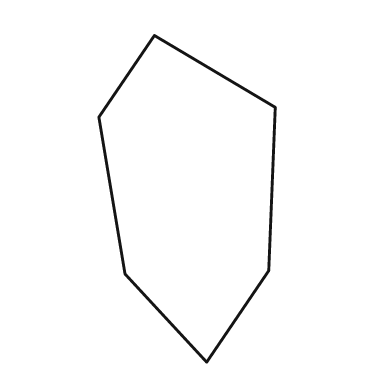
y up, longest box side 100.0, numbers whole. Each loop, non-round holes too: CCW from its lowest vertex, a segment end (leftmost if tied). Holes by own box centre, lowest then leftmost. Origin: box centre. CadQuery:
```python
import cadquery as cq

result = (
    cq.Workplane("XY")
    .moveTo(6.0, -50.0)
    .lineTo(25.0, -22.0)
    .lineTo(27.0, 28.0)
    .lineTo(-10.0, 50.0)
    .lineTo(-27.0, 25.0)
    .lineTo(-19.0, -23.0)
    .close()
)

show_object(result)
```